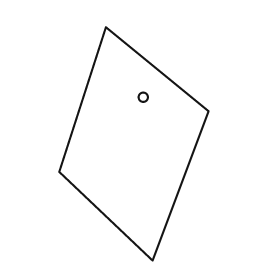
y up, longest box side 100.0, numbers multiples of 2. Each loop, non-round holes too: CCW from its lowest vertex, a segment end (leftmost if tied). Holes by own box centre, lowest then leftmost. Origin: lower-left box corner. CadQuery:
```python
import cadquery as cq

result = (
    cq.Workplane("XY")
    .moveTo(40.0, 0.0)
    .lineTo(64.0, 64.0)
    .lineTo(20.0, 100.0)
    .lineTo(0.0, 38.0)
    .close()
    .moveTo(36.0, 70.0)
    .circle(2.0)
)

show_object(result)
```